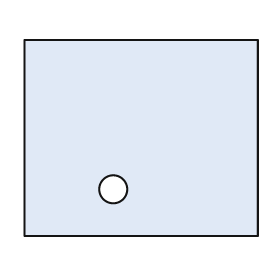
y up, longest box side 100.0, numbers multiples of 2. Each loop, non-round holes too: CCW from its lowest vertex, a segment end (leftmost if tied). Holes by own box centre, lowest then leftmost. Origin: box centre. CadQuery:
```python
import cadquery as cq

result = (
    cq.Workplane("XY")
    .moveTo(-50.0, -42.0)
    .lineTo(50.0, -42.0)
    .lineTo(50.0, 42.0)
    .lineTo(-50.0, 42.0)
    .close()
    .moveTo(-12.0, -22.0)
    .circle(6.0)
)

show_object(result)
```